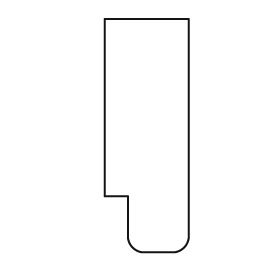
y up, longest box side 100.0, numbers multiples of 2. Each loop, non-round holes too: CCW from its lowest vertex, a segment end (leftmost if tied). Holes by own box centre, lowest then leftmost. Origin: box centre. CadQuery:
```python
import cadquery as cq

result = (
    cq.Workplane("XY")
    .moveTo(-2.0, -50.0)
    .lineTo(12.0, -50.0)
    .threePointArc((16.0, -48.0), (18.0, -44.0))
    .lineTo(18.0, 50.0)
    .lineTo(-18.0, 50.0)
    .lineTo(-18.0, -26.0)
    .lineTo(-8.0, -26.0)
    .lineTo(-8.0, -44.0)
    .threePointArc((-6.0, -48.0), (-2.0, -50.0))
    .close()
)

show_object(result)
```